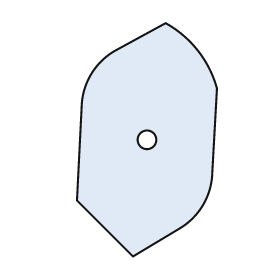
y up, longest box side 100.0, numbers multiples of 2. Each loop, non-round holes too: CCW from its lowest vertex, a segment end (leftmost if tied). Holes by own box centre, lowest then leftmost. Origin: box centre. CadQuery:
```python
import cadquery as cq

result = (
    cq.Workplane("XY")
    .moveTo(-6.0, -50.0)
    .lineTo(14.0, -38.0)
    .threePointArc((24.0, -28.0), (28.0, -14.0))
    .lineTo(30.0, 22.0)
    .threePointArc((22.0, 38.0), (8.0, 50.0))
    .lineTo(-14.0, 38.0)
    .threePointArc((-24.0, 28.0), (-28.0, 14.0))
    .lineTo(-30.0, -26.0)
    .close()
    .moveTo(0.0, 0.0)
    .circle(4.0)
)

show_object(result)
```